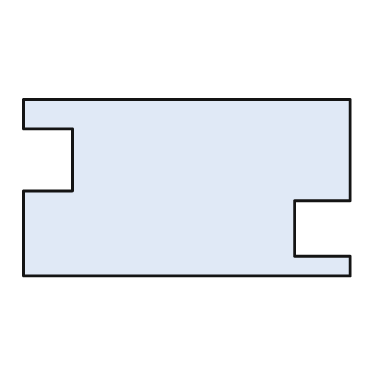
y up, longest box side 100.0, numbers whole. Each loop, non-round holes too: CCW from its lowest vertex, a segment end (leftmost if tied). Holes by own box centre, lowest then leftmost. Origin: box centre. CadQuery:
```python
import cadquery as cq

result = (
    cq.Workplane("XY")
    .moveTo(-50.0, -27.0)
    .lineTo(50.0, -27.0)
    .lineTo(50.0, -21.0)
    .lineTo(33.0, -21.0)
    .lineTo(33.0, -4.0)
    .lineTo(50.0, -4.0)
    .lineTo(50.0, 27.0)
    .lineTo(-50.0, 27.0)
    .lineTo(-50.0, 18.0)
    .lineTo(-35.0, 18.0)
    .lineTo(-35.0, -1.0)
    .lineTo(-50.0, -1.0)
    .close()
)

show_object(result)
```